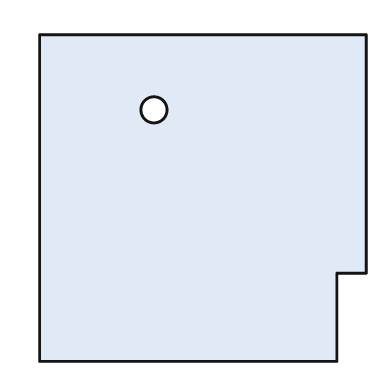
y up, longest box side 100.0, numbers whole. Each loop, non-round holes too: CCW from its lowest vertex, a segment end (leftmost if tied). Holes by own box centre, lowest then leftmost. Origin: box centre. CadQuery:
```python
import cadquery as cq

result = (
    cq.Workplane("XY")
    .moveTo(-50.0, -50.0)
    .lineTo(41.0, -50.0)
    .lineTo(41.0, -23.0)
    .lineTo(50.0, -23.0)
    .lineTo(50.0, 50.0)
    .lineTo(-50.0, 50.0)
    .close()
    .moveTo(-15.0, 27.0)
    .circle(4.0)
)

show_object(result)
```